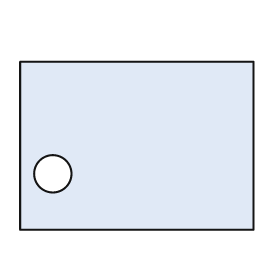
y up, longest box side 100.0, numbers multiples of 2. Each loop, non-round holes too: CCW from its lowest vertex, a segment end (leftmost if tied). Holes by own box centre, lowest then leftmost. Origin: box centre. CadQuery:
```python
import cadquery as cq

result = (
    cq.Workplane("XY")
    .moveTo(-50.0, -36.0)
    .lineTo(50.0, -36.0)
    .lineTo(50.0, 36.0)
    .lineTo(-50.0, 36.0)
    .close()
    .moveTo(-36.0, -12.0)
    .circle(8.0)
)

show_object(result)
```